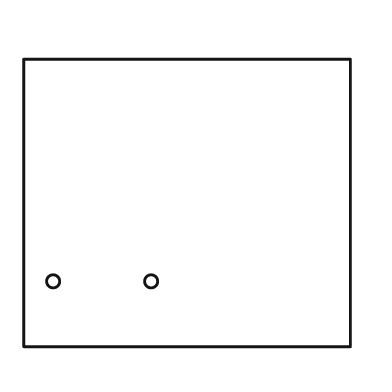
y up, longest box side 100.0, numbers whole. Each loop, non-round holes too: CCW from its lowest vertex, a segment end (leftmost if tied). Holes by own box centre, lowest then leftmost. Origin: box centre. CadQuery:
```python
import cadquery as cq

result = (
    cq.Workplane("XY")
    .moveTo(-50.0, -44.0)
    .lineTo(50.0, -44.0)
    .lineTo(50.0, 44.0)
    .lineTo(-50.0, 44.0)
    .close()
    .moveTo(-41.0, -24.0)
    .circle(2.0)
    .moveTo(-11.0, -24.0)
    .circle(2.0)
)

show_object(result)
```